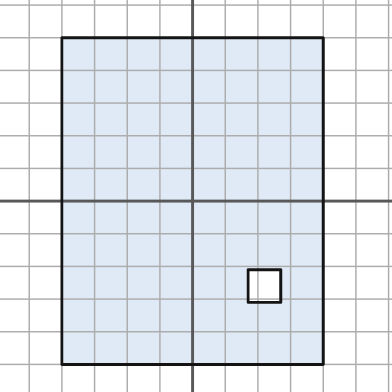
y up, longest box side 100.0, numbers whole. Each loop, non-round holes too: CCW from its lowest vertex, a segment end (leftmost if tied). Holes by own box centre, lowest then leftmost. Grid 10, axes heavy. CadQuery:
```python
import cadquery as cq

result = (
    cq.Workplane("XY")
    .moveTo(-40.0, -50.0)
    .lineTo(40.0, -50.0)
    .lineTo(40.0, 50.0)
    .lineTo(-40.0, 50.0)
    .close()
    .moveTo(17.0, -31.0)
    .lineTo(27.0, -31.0)
    .lineTo(27.0, -21.0)
    .lineTo(17.0, -21.0)
    .close()
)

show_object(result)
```